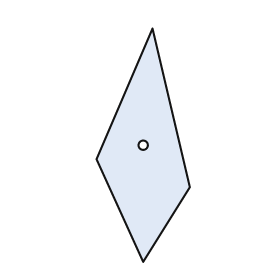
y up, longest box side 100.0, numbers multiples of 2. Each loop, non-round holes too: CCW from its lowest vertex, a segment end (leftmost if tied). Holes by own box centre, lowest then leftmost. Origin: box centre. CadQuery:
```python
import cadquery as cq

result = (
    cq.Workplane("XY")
    .moveTo(0.0, -50.0)
    .lineTo(20.0, -18.0)
    .lineTo(4.0, 50.0)
    .lineTo(-20.0, -6.0)
    .close()
    .moveTo(0.0, 0.0)
    .circle(2.0)
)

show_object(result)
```